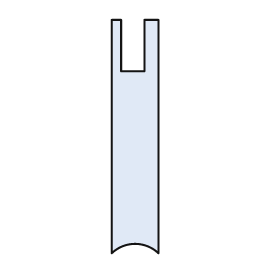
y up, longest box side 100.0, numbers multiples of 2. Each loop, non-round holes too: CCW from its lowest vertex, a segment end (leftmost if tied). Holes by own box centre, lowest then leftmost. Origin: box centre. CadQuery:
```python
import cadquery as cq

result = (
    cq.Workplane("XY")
    .moveTo(-10.0, -50.0)
    .threePointArc((0.0, -46.0), (10.0, -50.0))
    .lineTo(10.0, 50.0)
    .lineTo(4.0, 50.0)
    .lineTo(4.0, 28.0)
    .lineTo(-6.0, 28.0)
    .lineTo(-6.0, 50.0)
    .lineTo(-10.0, 50.0)
    .close()
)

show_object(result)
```